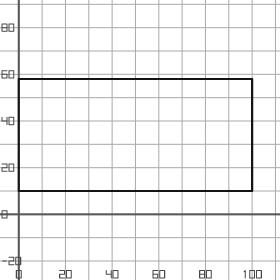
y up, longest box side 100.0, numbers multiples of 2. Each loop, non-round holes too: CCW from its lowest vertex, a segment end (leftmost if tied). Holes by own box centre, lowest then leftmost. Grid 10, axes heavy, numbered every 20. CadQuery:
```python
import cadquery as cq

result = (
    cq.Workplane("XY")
    .moveTo(0.0, 10.0)
    .lineTo(100.0, 10.0)
    .lineTo(100.0, 58.0)
    .lineTo(0.0, 58.0)
    .close()
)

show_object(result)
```